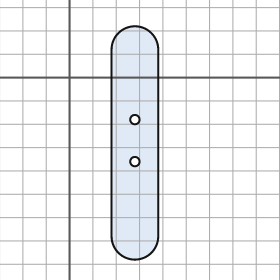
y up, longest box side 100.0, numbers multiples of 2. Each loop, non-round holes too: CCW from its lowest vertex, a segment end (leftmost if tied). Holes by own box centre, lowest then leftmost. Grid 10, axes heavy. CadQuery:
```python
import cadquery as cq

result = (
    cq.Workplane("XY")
    .moveTo(18.0, -68.0)
    .threePointArc((28.0, -78.0), (38.0, -68.0))
    .lineTo(38.0, 12.0)
    .threePointArc((28.0, 22.0), (18.0, 12.0))
    .close()
    .moveTo(28.0, -36.0)
    .circle(2.0)
    .moveTo(28.0, -18.0)
    .circle(2.0)
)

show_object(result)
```